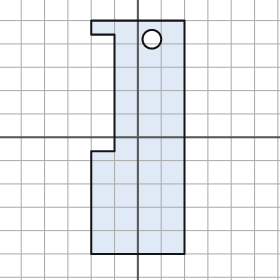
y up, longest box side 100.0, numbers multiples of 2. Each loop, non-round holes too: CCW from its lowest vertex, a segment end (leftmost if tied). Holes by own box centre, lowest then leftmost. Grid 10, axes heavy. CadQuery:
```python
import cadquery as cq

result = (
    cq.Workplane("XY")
    .moveTo(-20.0, -50.0)
    .lineTo(20.0, -50.0)
    .lineTo(20.0, 50.0)
    .lineTo(-20.0, 50.0)
    .lineTo(-20.0, 44.0)
    .lineTo(-10.0, 44.0)
    .lineTo(-10.0, -6.0)
    .lineTo(-20.0, -6.0)
    .close()
    .moveTo(6.0, 42.0)
    .circle(4.0)
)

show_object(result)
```